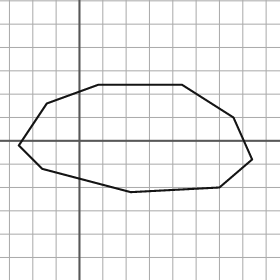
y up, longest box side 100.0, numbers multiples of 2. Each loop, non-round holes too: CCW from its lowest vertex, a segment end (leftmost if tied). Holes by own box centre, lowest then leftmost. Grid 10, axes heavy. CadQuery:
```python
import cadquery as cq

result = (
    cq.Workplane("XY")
    .moveTo(22.0, -22.0)
    .lineTo(60.0, -20.0)
    .lineTo(74.0, -8.0)
    .lineTo(66.0, 10.0)
    .lineTo(44.0, 24.0)
    .lineTo(8.0, 24.0)
    .lineTo(-14.0, 16.0)
    .lineTo(-26.0, -2.0)
    .lineTo(-16.0, -12.0)
    .close()
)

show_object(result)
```